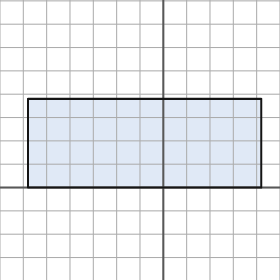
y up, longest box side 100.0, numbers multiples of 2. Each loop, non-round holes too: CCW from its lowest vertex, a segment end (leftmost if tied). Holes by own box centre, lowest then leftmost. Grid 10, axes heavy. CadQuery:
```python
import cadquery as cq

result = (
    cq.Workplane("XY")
    .moveTo(-58.0, 0.0)
    .lineTo(42.0, 0.0)
    .lineTo(42.0, 38.0)
    .lineTo(-58.0, 38.0)
    .close()
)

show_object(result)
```